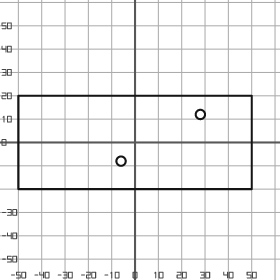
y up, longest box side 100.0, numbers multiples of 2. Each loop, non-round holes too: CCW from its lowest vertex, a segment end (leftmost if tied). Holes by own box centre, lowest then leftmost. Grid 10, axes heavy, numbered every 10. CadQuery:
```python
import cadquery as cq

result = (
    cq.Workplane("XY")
    .moveTo(-50.0, -20.0)
    .lineTo(50.0, -20.0)
    .lineTo(50.0, 20.0)
    .lineTo(-50.0, 20.0)
    .close()
    .moveTo(-6.0, -8.0)
    .circle(2.0)
    .moveTo(28.0, 12.0)
    .circle(2.0)
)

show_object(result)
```